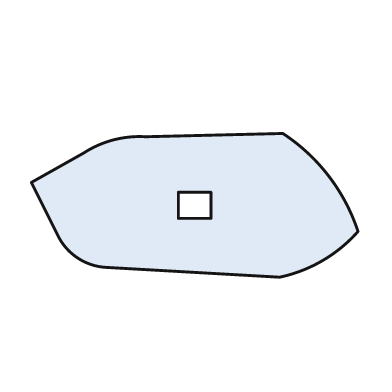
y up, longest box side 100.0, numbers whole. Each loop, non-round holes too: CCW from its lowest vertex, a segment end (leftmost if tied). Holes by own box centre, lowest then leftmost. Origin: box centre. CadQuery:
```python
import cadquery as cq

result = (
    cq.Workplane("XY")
    .moveTo(26.0, -22.0)
    .threePointArc((39.0, -17.0), (50.0, -8.0))
    .threePointArc((41.0, 9.0), (27.0, 22.0))
    .lineTo(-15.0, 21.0)
    .threePointArc((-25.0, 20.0), (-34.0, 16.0))
    .lineTo(-50.0, 7.0)
    .lineTo(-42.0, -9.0)
    .threePointArc((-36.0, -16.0), (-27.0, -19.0))
    .close()
    .moveTo(-5.0, -4.0)
    .lineTo(5.0, -4.0)
    .lineTo(5.0, 4.0)
    .lineTo(-5.0, 4.0)
    .close()
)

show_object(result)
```